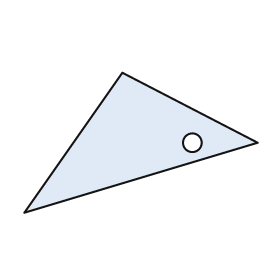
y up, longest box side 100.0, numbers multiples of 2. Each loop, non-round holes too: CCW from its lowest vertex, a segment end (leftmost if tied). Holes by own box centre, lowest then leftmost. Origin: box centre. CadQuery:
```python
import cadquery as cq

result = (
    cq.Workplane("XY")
    .moveTo(-50.0, -30.0)
    .lineTo(50.0, 0.0)
    .lineTo(-8.0, 30.0)
    .close()
    .moveTo(22.0, 0.0)
    .circle(4.0)
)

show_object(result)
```